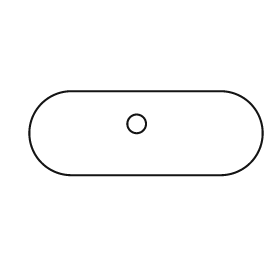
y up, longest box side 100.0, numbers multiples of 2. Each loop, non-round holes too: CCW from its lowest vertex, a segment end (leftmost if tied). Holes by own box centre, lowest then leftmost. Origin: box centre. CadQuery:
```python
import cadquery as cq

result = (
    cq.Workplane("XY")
    .moveTo(-32.0, -18.0)
    .lineTo(32.0, -18.0)
    .threePointArc((50.0, 0.0), (32.0, 18.0))
    .lineTo(-32.0, 18.0)
    .threePointArc((-50.0, 0.0), (-32.0, -18.0))
    .close()
    .moveTo(-4.0, 4.0)
    .circle(4.0)
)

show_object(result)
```